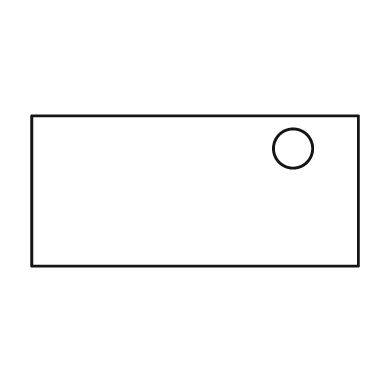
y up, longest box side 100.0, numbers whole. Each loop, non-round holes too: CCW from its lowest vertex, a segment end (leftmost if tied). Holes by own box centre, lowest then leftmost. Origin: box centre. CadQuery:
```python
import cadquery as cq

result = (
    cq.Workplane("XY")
    .moveTo(-50.0, -23.0)
    .lineTo(50.0, -23.0)
    .lineTo(50.0, 23.0)
    .lineTo(-50.0, 23.0)
    .close()
    .moveTo(30.0, 13.0)
    .circle(6.0)
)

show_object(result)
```